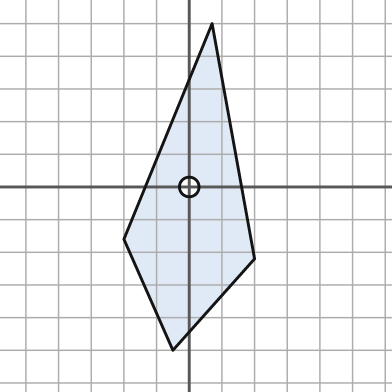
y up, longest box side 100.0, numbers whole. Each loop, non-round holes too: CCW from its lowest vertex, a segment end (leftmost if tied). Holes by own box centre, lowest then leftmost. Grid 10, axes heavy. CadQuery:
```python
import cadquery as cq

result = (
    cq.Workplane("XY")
    .moveTo(-5.0, -50.0)
    .lineTo(20.0, -22.0)
    .lineTo(7.0, 50.0)
    .lineTo(-20.0, -16.0)
    .close()
    .moveTo(0.0, 0.0)
    .circle(3.0)
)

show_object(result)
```